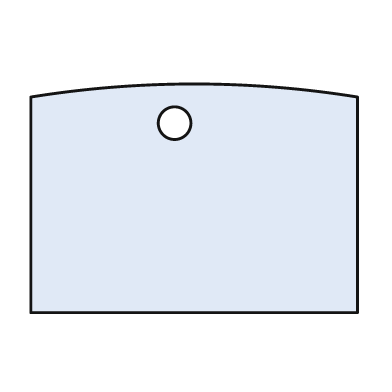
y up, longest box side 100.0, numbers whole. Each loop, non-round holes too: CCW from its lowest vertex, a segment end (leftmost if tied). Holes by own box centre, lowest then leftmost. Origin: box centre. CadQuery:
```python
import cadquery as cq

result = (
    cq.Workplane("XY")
    .moveTo(-50.0, -35.0)
    .lineTo(50.0, -35.0)
    .lineTo(50.0, 31.0)
    .threePointArc((0.0, 35.0), (-50.0, 31.0))
    .close()
    .moveTo(-6.0, 23.0)
    .circle(5.0)
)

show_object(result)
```